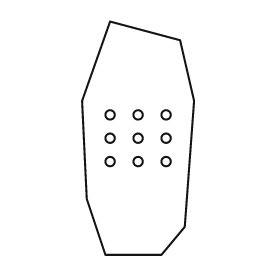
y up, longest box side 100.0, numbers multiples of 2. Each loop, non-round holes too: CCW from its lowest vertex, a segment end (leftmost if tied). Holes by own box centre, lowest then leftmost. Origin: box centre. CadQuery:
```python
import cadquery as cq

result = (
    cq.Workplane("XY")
    .moveTo(-14.0, -50.0)
    .lineTo(10.0, -50.0)
    .lineTo(20.0, -38.0)
    .lineTo(24.0, 16.0)
    .lineTo(18.0, 42.0)
    .lineTo(-12.0, 50.0)
    .lineTo(-24.0, 16.0)
    .lineTo(-22.0, -26.0)
    .close()
    .moveTo(-12.0, -10.0)
    .circle(2.0)
    .moveTo(0.0, -10.0)
    .circle(2.0)
    .moveTo(12.0, -10.0)
    .circle(2.0)
    .moveTo(-12.0, 0.0)
    .circle(2.0)
    .moveTo(0.0, 0.0)
    .circle(2.0)
    .moveTo(12.0, 0.0)
    .circle(2.0)
    .moveTo(-12.0, 10.0)
    .circle(2.0)
    .moveTo(0.0, 10.0)
    .circle(2.0)
    .moveTo(12.0, 10.0)
    .circle(2.0)
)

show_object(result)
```